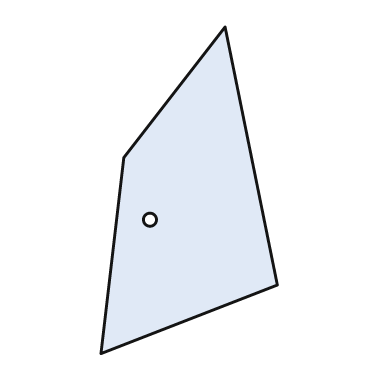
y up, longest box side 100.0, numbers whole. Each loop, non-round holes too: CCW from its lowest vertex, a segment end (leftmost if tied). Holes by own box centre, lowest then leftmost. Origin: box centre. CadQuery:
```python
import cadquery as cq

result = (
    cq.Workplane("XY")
    .moveTo(-27.0, -50.0)
    .lineTo(27.0, -29.0)
    .lineTo(11.0, 50.0)
    .lineTo(-20.0, 10.0)
    .close()
    .moveTo(-12.0, -9.0)
    .circle(2.0)
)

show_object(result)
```